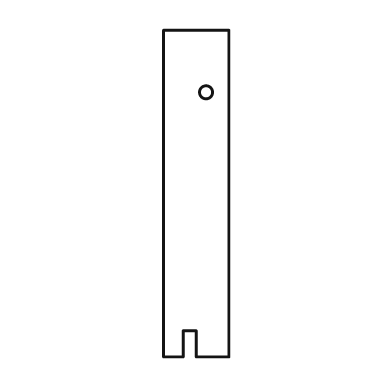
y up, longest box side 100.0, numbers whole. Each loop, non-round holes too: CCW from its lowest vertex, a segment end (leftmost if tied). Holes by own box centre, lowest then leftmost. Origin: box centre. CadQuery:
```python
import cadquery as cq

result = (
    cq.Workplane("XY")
    .moveTo(-10.0, -50.0)
    .lineTo(-4.0, -50.0)
    .lineTo(-4.0, -42.0)
    .lineTo(0.0, -42.0)
    .lineTo(0.0, -50.0)
    .lineTo(10.0, -50.0)
    .lineTo(10.0, 50.0)
    .lineTo(-10.0, 50.0)
    .close()
    .moveTo(3.0, 31.0)
    .circle(2.0)
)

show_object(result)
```